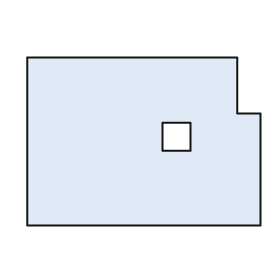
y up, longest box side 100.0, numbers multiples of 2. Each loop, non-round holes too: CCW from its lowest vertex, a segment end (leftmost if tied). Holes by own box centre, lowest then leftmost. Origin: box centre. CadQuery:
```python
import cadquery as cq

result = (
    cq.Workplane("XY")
    .moveTo(-50.0, -36.0)
    .lineTo(50.0, -36.0)
    .lineTo(50.0, 12.0)
    .lineTo(40.0, 12.0)
    .lineTo(40.0, 36.0)
    .lineTo(-50.0, 36.0)
    .close()
    .moveTo(8.0, -4.0)
    .lineTo(20.0, -4.0)
    .lineTo(20.0, 8.0)
    .lineTo(8.0, 8.0)
    .close()
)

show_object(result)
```